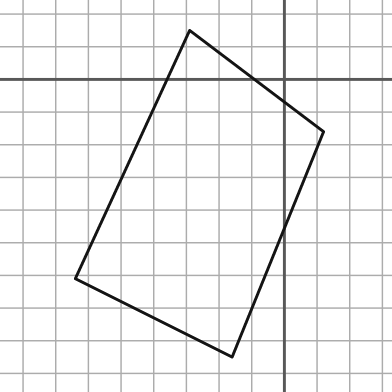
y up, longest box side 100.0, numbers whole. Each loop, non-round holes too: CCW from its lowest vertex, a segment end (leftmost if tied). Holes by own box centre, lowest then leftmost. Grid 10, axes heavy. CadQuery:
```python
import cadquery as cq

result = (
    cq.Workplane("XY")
    .moveTo(-16.0, -85.0)
    .lineTo(12.0, -16.0)
    .lineTo(-29.0, 15.0)
    .lineTo(-64.0, -61.0)
    .close()
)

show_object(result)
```